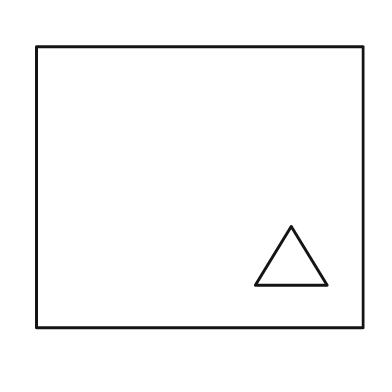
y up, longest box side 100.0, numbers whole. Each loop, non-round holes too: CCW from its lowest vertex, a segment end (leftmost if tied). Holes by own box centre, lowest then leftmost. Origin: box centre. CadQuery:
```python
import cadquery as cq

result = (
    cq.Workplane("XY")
    .moveTo(-50.0, -43.0)
    .lineTo(50.0, -43.0)
    .lineTo(50.0, 43.0)
    .lineTo(-50.0, 43.0)
    .close()
    .moveTo(17.0, -30.0)
    .lineTo(39.0, -30.0)
    .lineTo(28.0, -12.0)
    .close()
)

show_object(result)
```